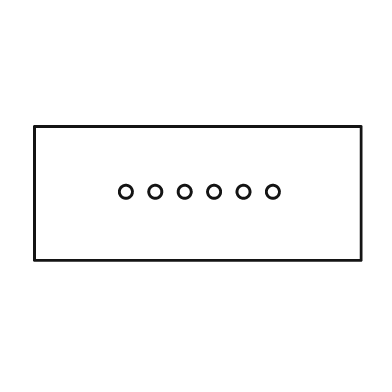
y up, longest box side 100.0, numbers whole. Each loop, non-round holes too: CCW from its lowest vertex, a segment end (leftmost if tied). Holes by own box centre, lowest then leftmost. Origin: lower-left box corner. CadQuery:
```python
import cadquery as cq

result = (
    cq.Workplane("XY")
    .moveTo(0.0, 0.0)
    .lineTo(100.0, 0.0)
    .lineTo(100.0, 41.0)
    .lineTo(0.0, 41.0)
    .close()
    .moveTo(28.0, 21.0)
    .circle(2.0)
    .moveTo(37.0, 21.0)
    .circle(2.0)
    .moveTo(46.0, 21.0)
    .circle(2.0)
    .moveTo(55.0, 21.0)
    .circle(2.0)
    .moveTo(64.0, 21.0)
    .circle(2.0)
    .moveTo(73.0, 21.0)
    .circle(2.0)
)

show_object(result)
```